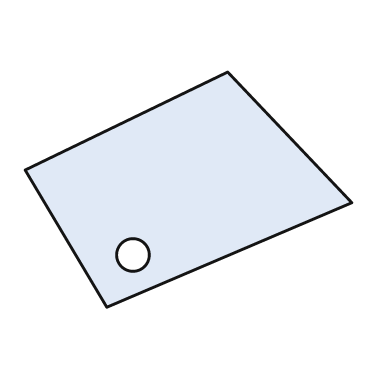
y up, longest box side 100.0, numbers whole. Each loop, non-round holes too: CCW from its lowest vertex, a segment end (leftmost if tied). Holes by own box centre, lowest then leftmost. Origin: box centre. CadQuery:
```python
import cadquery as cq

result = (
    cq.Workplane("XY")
    .moveTo(-25.0, -36.0)
    .lineTo(50.0, -4.0)
    .lineTo(12.0, 36.0)
    .lineTo(-50.0, 6.0)
    .close()
    .moveTo(-17.0, -20.0)
    .circle(5.0)
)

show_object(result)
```